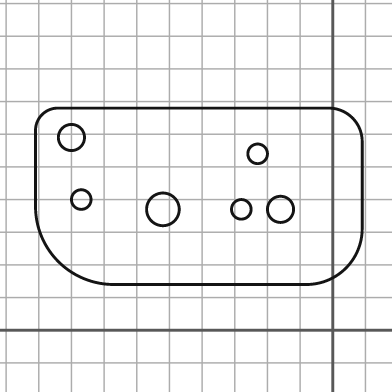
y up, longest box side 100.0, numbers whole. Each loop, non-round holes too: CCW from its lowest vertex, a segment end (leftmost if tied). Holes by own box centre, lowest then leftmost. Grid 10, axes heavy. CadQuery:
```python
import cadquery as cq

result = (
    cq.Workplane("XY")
    .moveTo(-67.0, 14.0)
    .lineTo(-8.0, 14.0)
    .threePointArc((4.0, 19.0), (9.0, 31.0))
    .lineTo(9.0, 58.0)
    .threePointArc((6.0, 65.0), (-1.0, 68.0))
    .lineTo(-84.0, 68.0)
    .threePointArc((-89.0, 66.0), (-91.0, 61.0))
    .lineTo(-91.0, 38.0)
    .threePointArc((-84.0, 21.0), (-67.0, 14.0))
    .close()
    .moveTo(-52.0, 37.0)
    .circle(5.0)
    .moveTo(-28.0, 37.0)
    .circle(3.0)
    .moveTo(-16.0, 37.0)
    .circle(4.0)
    .moveTo(-77.0, 40.0)
    .circle(3.0)
    .moveTo(-23.0, 54.0)
    .circle(3.0)
    .moveTo(-80.0, 59.0)
    .circle(4.0)
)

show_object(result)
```